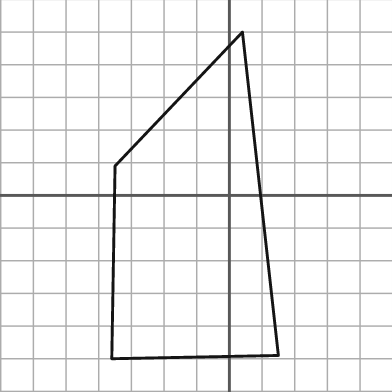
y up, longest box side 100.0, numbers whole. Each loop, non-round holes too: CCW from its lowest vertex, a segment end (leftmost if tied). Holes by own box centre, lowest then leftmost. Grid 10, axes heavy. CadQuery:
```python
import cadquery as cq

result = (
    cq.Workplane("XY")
    .moveTo(-36.0, -50.0)
    .lineTo(15.0, -49.0)
    .lineTo(4.0, 50.0)
    .lineTo(-35.0, 9.0)
    .close()
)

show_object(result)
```